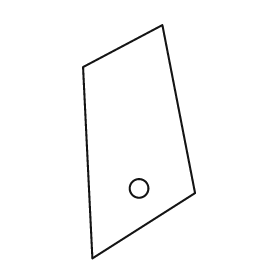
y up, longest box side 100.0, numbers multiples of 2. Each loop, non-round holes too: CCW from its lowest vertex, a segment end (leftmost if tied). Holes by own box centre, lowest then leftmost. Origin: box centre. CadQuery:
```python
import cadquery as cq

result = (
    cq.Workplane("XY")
    .moveTo(-20.0, -50.0)
    .lineTo(24.0, -22.0)
    .lineTo(10.0, 50.0)
    .lineTo(-24.0, 32.0)
    .close()
    .moveTo(0.0, -20.0)
    .circle(4.0)
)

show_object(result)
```